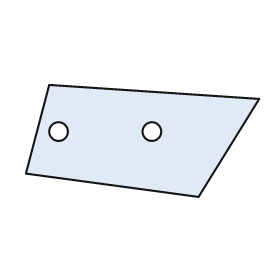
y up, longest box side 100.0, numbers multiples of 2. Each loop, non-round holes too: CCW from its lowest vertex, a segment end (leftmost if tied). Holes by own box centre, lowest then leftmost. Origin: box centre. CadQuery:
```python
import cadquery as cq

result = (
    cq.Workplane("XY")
    .moveTo(24.0, -24.0)
    .lineTo(50.0, 18.0)
    .lineTo(-40.0, 24.0)
    .lineTo(-50.0, -14.0)
    .close()
    .moveTo(-36.0, 4.0)
    .circle(4.0)
    .moveTo(4.0, 4.0)
    .circle(4.0)
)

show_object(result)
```